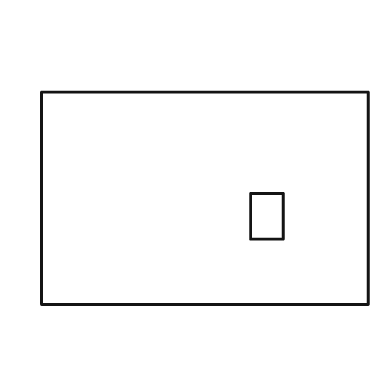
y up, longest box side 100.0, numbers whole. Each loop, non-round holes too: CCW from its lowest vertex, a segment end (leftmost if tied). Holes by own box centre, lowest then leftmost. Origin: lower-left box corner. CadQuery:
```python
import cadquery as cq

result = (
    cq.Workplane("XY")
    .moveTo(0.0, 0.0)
    .lineTo(100.0, 0.0)
    .lineTo(100.0, 65.0)
    .lineTo(0.0, 65.0)
    .close()
    .moveTo(64.0, 20.0)
    .lineTo(74.0, 20.0)
    .lineTo(74.0, 34.0)
    .lineTo(64.0, 34.0)
    .close()
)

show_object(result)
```